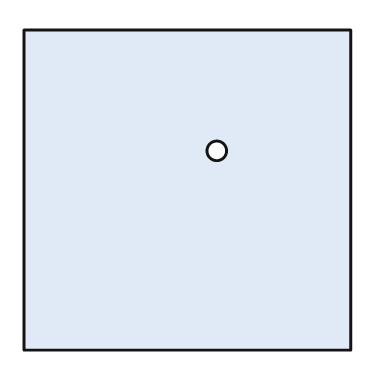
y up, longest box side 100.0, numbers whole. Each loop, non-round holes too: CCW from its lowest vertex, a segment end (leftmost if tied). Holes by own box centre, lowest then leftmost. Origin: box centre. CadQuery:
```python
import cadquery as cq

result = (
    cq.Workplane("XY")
    .moveTo(-50.0, -49.0)
    .lineTo(50.0, -49.0)
    .lineTo(50.0, 49.0)
    .lineTo(-50.0, 49.0)
    .close()
    .moveTo(9.0, 12.0)
    .circle(3.0)
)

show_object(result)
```